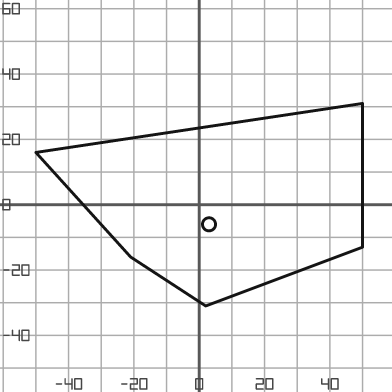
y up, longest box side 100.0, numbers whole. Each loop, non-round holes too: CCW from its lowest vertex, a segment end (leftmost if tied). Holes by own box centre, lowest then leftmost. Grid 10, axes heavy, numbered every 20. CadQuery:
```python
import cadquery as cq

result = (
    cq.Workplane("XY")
    .moveTo(2.0, -31.0)
    .lineTo(50.0, -13.0)
    .lineTo(50.0, 31.0)
    .lineTo(-50.0, 16.0)
    .lineTo(-21.0, -16.0)
    .close()
    .moveTo(3.0, -6.0)
    .circle(2.0)
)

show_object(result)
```